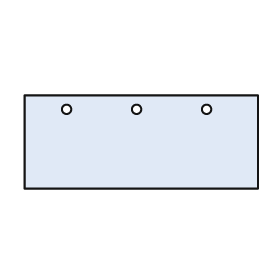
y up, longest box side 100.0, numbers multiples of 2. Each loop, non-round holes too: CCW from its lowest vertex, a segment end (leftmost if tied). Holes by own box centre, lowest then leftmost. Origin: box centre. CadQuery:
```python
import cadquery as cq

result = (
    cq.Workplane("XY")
    .moveTo(-50.0, -20.0)
    .lineTo(50.0, -20.0)
    .lineTo(50.0, 20.0)
    .lineTo(-50.0, 20.0)
    .close()
    .moveTo(-32.0, 14.0)
    .circle(2.0)
    .moveTo(-2.0, 14.0)
    .circle(2.0)
    .moveTo(28.0, 14.0)
    .circle(2.0)
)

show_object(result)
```